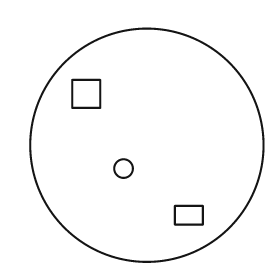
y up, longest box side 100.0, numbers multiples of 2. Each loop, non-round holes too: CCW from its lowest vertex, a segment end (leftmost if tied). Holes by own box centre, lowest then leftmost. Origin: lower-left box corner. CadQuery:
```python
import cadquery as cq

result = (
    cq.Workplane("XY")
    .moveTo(50.0, 50.0)
    .circle(50.0)
    .moveTo(62.0, 16.0)
    .lineTo(74.0, 16.0)
    .lineTo(74.0, 24.0)
    .lineTo(62.0, 24.0)
    .close()
    .moveTo(40.0, 40.0)
    .circle(4.0)
    .moveTo(18.0, 66.0)
    .lineTo(30.0, 66.0)
    .lineTo(30.0, 78.0)
    .lineTo(18.0, 78.0)
    .close()
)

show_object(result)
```